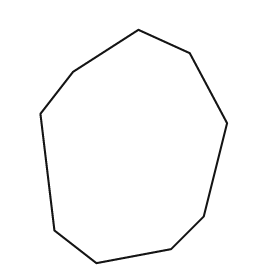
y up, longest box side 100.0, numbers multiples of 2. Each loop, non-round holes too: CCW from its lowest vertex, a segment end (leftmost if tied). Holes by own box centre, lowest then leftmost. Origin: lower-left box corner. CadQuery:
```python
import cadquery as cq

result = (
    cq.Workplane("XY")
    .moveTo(24.0, 0.0)
    .lineTo(56.0, 6.0)
    .lineTo(70.0, 20.0)
    .lineTo(80.0, 60.0)
    .lineTo(64.0, 90.0)
    .lineTo(42.0, 100.0)
    .lineTo(14.0, 82.0)
    .lineTo(0.0, 64.0)
    .lineTo(6.0, 14.0)
    .close()
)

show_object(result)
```